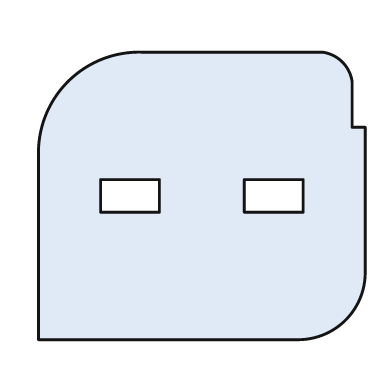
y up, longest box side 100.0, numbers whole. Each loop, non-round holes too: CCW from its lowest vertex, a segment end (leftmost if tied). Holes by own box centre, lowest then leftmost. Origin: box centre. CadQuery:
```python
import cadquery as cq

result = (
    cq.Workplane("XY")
    .moveTo(-50.0, -44.0)
    .lineTo(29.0, -44.0)
    .threePointArc((44.0, -38.0), (50.0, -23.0))
    .lineTo(50.0, 21.0)
    .lineTo(46.0, 21.0)
    .lineTo(46.0, 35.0)
    .threePointArc((43.0, 41.0), (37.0, 44.0))
    .lineTo(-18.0, 44.0)
    .threePointArc((-41.0, 35.0), (-50.0, 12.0))
    .close()
    .moveTo(-31.0, -5.0)
    .lineTo(-13.0, -5.0)
    .lineTo(-13.0, 5.0)
    .lineTo(-31.0, 5.0)
    .close()
    .moveTo(13.0, -5.0)
    .lineTo(31.0, -5.0)
    .lineTo(31.0, 5.0)
    .lineTo(13.0, 5.0)
    .close()
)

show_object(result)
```